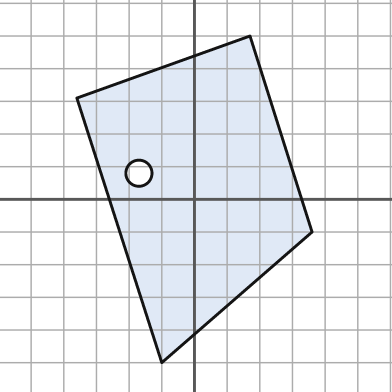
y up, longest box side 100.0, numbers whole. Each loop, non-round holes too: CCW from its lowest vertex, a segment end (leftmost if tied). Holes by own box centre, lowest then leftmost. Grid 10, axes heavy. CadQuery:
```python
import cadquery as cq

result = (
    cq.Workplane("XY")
    .moveTo(-10.0, -50.0)
    .lineTo(36.0, -10.0)
    .lineTo(17.0, 50.0)
    .lineTo(-36.0, 31.0)
    .close()
    .moveTo(-17.0, 8.0)
    .circle(4.0)
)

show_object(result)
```